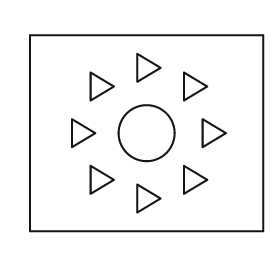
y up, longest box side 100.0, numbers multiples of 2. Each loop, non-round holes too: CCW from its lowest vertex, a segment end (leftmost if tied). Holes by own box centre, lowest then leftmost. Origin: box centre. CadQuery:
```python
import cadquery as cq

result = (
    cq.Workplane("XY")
    .moveTo(-50.0, -42.0)
    .lineTo(50.0, -42.0)
    .lineTo(50.0, 42.0)
    .lineTo(-50.0, 42.0)
    .close()
    .moveTo(-4.0, -34.0)
    .lineTo(6.0, -28.0)
    .lineTo(-4.0, -22.0)
    .close()
    .moveTo(-24.0, -26.0)
    .lineTo(-14.0, -20.0)
    .lineTo(-24.0, -14.0)
    .close()
    .moveTo(16.0, -26.0)
    .lineTo(26.0, -20.0)
    .lineTo(16.0, -14.0)
    .close()
    .moveTo(-32.0, -6.0)
    .lineTo(-22.0, 0.0)
    .lineTo(-32.0, 6.0)
    .close()
    .moveTo(0.0, 0.0)
    .circle(12.0)
    .moveTo(24.0, -6.0)
    .lineTo(34.0, 0.0)
    .lineTo(24.0, 6.0)
    .close()
    .moveTo(-24.0, 14.0)
    .lineTo(-14.0, 20.0)
    .lineTo(-24.0, 26.0)
    .close()
    .moveTo(16.0, 14.0)
    .lineTo(26.0, 20.0)
    .lineTo(16.0, 26.0)
    .close()
    .moveTo(-4.0, 22.0)
    .lineTo(6.0, 28.0)
    .lineTo(-4.0, 34.0)
    .close()
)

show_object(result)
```